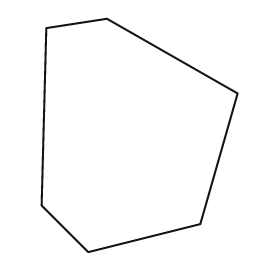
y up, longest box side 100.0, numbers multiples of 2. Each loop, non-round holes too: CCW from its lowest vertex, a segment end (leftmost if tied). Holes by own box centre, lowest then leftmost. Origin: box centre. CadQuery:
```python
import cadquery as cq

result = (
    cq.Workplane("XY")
    .moveTo(-22.0, -50.0)
    .lineTo(26.0, -38.0)
    .lineTo(42.0, 18.0)
    .lineTo(-14.0, 50.0)
    .lineTo(-40.0, 46.0)
    .lineTo(-42.0, -30.0)
    .close()
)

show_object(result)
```